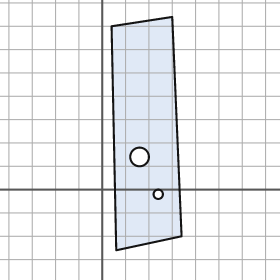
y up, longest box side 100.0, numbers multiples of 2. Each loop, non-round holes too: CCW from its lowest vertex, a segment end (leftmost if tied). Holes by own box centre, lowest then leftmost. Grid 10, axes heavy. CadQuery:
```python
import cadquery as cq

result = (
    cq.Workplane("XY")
    .moveTo(6.0, -26.0)
    .lineTo(34.0, -20.0)
    .lineTo(30.0, 74.0)
    .lineTo(4.0, 70.0)
    .close()
    .moveTo(24.0, -2.0)
    .circle(2.0)
    .moveTo(16.0, 14.0)
    .circle(4.0)
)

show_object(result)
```